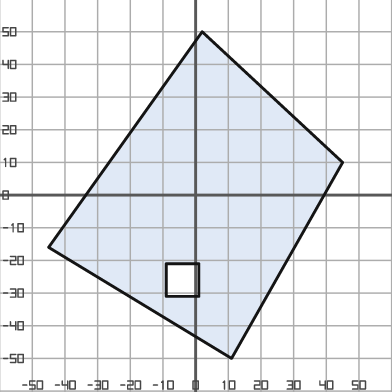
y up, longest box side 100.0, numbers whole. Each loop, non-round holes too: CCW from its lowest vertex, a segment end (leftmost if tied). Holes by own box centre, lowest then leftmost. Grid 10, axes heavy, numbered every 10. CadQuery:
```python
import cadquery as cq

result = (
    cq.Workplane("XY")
    .moveTo(11.0, -50.0)
    .lineTo(45.0, 10.0)
    .lineTo(2.0, 50.0)
    .lineTo(-45.0, -16.0)
    .close()
    .moveTo(-9.0, -31.0)
    .lineTo(1.0, -31.0)
    .lineTo(1.0, -21.0)
    .lineTo(-9.0, -21.0)
    .close()
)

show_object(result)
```